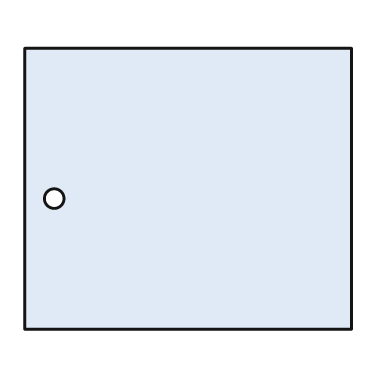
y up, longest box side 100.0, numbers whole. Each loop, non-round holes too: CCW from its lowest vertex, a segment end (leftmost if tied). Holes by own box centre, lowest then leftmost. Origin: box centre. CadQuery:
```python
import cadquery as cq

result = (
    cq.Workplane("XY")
    .moveTo(-50.0, -43.0)
    .lineTo(50.0, -43.0)
    .lineTo(50.0, 43.0)
    .lineTo(-50.0, 43.0)
    .close()
    .moveTo(-41.0, -3.0)
    .circle(3.0)
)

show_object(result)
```